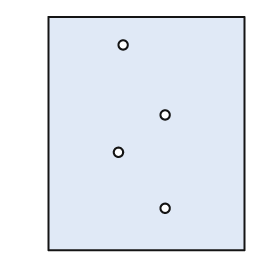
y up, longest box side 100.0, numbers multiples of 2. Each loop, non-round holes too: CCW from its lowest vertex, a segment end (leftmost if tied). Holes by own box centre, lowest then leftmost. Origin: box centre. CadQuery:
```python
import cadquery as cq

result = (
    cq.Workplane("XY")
    .moveTo(-42.0, -50.0)
    .lineTo(42.0, -50.0)
    .lineTo(42.0, 50.0)
    .lineTo(-42.0, 50.0)
    .close()
    .moveTo(8.0, -32.0)
    .circle(2.0)
    .moveTo(-12.0, -8.0)
    .circle(2.0)
    .moveTo(8.0, 8.0)
    .circle(2.0)
    .moveTo(-10.0, 38.0)
    .circle(2.0)
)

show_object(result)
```